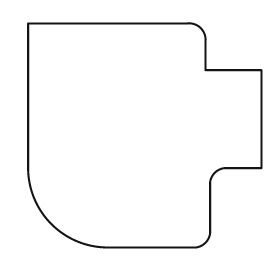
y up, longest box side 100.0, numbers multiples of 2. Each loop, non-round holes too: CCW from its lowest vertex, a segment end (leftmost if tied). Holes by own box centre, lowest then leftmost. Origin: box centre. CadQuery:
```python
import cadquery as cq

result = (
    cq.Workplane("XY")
    .moveTo(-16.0, -48.0)
    .lineTo(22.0, -48.0)
    .threePointArc((26.0, -46.0), (28.0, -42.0))
    .lineTo(28.0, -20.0)
    .threePointArc((30.0, -16.0), (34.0, -14.0))
    .lineTo(50.0, -14.0)
    .lineTo(50.0, 28.0)
    .lineTo(26.0, 28.0)
    .lineTo(26.0, 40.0)
    .threePointArc((24.0, 46.0), (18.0, 48.0))
    .lineTo(-50.0, 48.0)
    .lineTo(-50.0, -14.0)
    .threePointArc((-40.0, -38.0), (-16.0, -48.0))
    .close()
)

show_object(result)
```